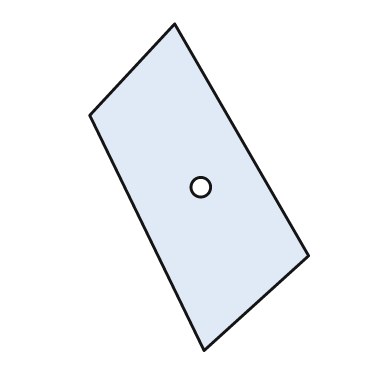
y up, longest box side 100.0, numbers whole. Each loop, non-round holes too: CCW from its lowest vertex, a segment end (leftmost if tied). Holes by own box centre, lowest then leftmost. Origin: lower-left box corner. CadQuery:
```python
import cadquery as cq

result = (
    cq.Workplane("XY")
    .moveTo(35.0, 0.0)
    .lineTo(67.0, 29.0)
    .lineTo(26.0, 100.0)
    .lineTo(0.0, 72.0)
    .close()
    .moveTo(34.0, 50.0)
    .circle(3.0)
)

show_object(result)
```